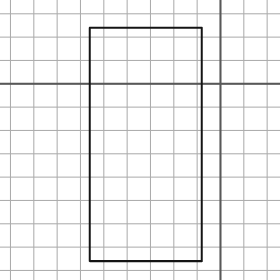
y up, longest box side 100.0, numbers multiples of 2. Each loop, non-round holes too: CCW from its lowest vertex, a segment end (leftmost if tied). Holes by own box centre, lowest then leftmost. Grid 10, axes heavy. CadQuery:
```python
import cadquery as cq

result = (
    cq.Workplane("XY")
    .moveTo(-56.0, -76.0)
    .lineTo(-8.0, -76.0)
    .lineTo(-8.0, 24.0)
    .lineTo(-56.0, 24.0)
    .close()
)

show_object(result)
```